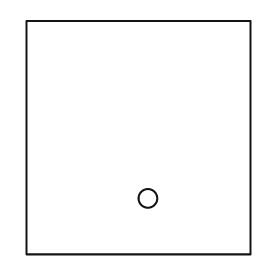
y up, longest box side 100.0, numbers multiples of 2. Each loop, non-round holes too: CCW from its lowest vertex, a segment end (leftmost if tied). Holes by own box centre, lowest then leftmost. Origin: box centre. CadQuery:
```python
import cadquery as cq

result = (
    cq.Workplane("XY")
    .moveTo(-48.0, -50.0)
    .lineTo(48.0, -50.0)
    .lineTo(48.0, 50.0)
    .lineTo(-48.0, 50.0)
    .close()
    .moveTo(4.0, -26.0)
    .circle(4.0)
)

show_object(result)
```